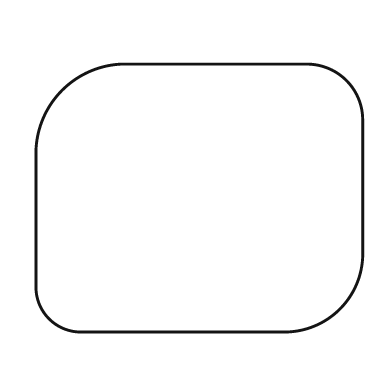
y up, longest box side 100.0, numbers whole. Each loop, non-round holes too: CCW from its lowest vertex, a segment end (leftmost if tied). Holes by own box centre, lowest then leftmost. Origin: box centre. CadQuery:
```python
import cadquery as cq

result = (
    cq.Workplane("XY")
    .moveTo(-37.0, -41.0)
    .lineTo(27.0, -41.0)
    .threePointArc((43.0, -34.0), (50.0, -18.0))
    .lineTo(50.0, 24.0)
    .threePointArc((45.0, 36.0), (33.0, 41.0))
    .lineTo(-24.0, 41.0)
    .threePointArc((-42.0, 33.0), (-50.0, 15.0))
    .lineTo(-50.0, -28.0)
    .threePointArc((-46.0, -37.0), (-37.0, -41.0))
    .close()
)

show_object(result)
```